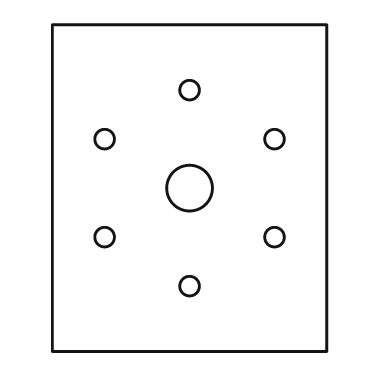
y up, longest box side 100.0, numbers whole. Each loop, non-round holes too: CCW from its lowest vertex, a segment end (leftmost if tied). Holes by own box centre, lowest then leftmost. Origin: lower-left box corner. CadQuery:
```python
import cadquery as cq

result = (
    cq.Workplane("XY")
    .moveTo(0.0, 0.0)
    .lineTo(84.0, 0.0)
    .lineTo(84.0, 100.0)
    .lineTo(0.0, 100.0)
    .close()
    .moveTo(42.0, 20.0)
    .circle(3.0)
    .moveTo(16.0, 35.0)
    .circle(3.0)
    .moveTo(68.0, 35.0)
    .circle(3.0)
    .moveTo(42.0, 50.0)
    .circle(7.0)
    .moveTo(16.0, 65.0)
    .circle(3.0)
    .moveTo(68.0, 65.0)
    .circle(3.0)
    .moveTo(42.0, 80.0)
    .circle(3.0)
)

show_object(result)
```